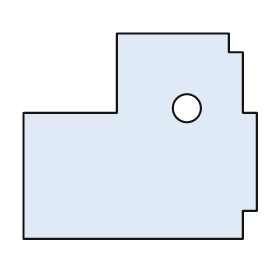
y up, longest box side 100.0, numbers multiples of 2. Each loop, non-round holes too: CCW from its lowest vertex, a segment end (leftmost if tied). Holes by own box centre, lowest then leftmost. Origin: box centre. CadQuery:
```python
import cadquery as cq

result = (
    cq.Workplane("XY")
    .moveTo(-50.0, -44.0)
    .lineTo(44.0, -44.0)
    .lineTo(44.0, -32.0)
    .lineTo(50.0, -32.0)
    .lineTo(50.0, 10.0)
    .lineTo(44.0, 10.0)
    .lineTo(44.0, 36.0)
    .lineTo(38.0, 36.0)
    .lineTo(38.0, 44.0)
    .lineTo(-10.0, 44.0)
    .lineTo(-10.0, 10.0)
    .lineTo(-50.0, 10.0)
    .close()
    .moveTo(20.0, 12.0)
    .circle(6.0)
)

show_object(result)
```